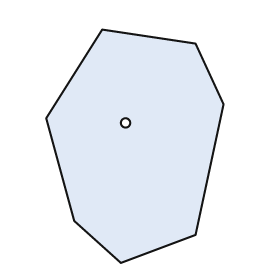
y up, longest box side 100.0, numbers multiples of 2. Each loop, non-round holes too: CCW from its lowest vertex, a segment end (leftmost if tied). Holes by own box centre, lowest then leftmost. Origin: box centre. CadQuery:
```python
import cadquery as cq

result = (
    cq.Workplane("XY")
    .moveTo(-6.0, -50.0)
    .lineTo(26.0, -38.0)
    .lineTo(38.0, 18.0)
    .lineTo(26.0, 44.0)
    .lineTo(-14.0, 50.0)
    .lineTo(-38.0, 12.0)
    .lineTo(-26.0, -32.0)
    .close()
    .moveTo(-4.0, 10.0)
    .circle(2.0)
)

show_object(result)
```